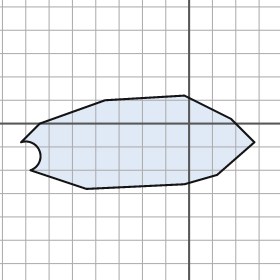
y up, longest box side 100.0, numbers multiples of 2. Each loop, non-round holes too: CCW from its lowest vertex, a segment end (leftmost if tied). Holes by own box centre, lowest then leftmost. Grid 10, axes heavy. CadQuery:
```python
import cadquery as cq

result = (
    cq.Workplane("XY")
    .moveTo(-44.0, -28.0)
    .lineTo(-2.0, -26.0)
    .lineTo(12.0, -22.0)
    .lineTo(28.0, -8.0)
    .lineTo(18.0, 2.0)
    .lineTo(-2.0, 12.0)
    .lineTo(-36.0, 10.0)
    .lineTo(-64.0, 0.0)
    .lineTo(-72.0, -8.0)
    .threePointArc((-64.0, -12.0), (-68.0, -20.0))
    .close()
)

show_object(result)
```